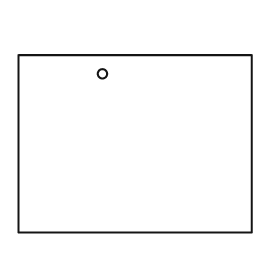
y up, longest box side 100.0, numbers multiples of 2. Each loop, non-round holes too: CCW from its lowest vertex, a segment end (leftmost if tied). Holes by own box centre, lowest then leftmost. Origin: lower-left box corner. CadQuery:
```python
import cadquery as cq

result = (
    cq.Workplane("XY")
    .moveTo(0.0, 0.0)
    .lineTo(100.0, 0.0)
    .lineTo(100.0, 76.0)
    .lineTo(0.0, 76.0)
    .close()
    .moveTo(36.0, 68.0)
    .circle(2.0)
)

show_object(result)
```